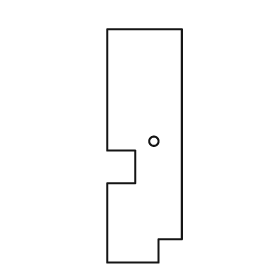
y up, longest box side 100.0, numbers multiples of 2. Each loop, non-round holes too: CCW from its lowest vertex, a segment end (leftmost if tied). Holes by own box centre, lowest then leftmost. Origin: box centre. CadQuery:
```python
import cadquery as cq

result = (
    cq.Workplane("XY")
    .moveTo(-16.0, -50.0)
    .lineTo(6.0, -50.0)
    .lineTo(6.0, -40.0)
    .lineTo(16.0, -40.0)
    .lineTo(16.0, 50.0)
    .lineTo(-16.0, 50.0)
    .lineTo(-16.0, -2.0)
    .lineTo(-4.0, -2.0)
    .lineTo(-4.0, -16.0)
    .lineTo(-16.0, -16.0)
    .close()
    .moveTo(4.0, 2.0)
    .circle(2.0)
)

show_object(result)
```